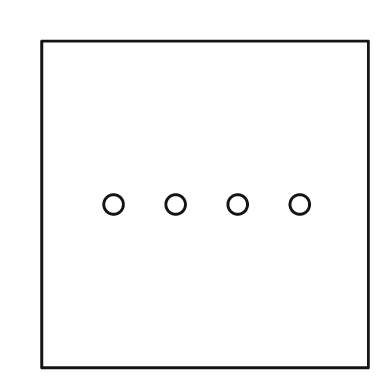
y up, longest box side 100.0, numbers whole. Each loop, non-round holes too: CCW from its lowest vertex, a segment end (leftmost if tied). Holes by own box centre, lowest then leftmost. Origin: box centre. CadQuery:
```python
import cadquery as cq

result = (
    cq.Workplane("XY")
    .moveTo(-50.0, -50.0)
    .lineTo(50.0, -50.0)
    .lineTo(50.0, 50.0)
    .lineTo(-50.0, 50.0)
    .close()
    .moveTo(-28.0, 0.0)
    .circle(3.0)
    .moveTo(-9.0, 0.0)
    .circle(3.0)
    .moveTo(10.0, 0.0)
    .circle(3.0)
    .moveTo(29.0, 0.0)
    .circle(3.0)
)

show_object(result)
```